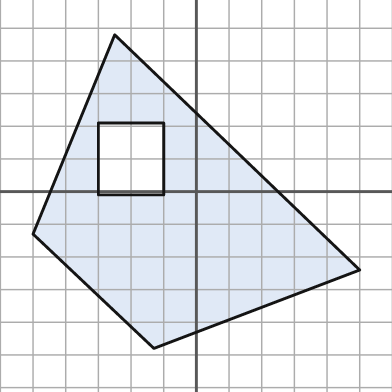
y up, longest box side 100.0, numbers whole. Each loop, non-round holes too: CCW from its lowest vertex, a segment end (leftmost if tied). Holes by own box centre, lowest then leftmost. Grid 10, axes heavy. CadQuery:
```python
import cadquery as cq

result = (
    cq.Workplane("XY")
    .moveTo(-13.0, -48.0)
    .lineTo(50.0, -24.0)
    .lineTo(-25.0, 48.0)
    .lineTo(-50.0, -13.0)
    .close()
    .moveTo(-30.0, -1.0)
    .lineTo(-10.0, -1.0)
    .lineTo(-10.0, 21.0)
    .lineTo(-30.0, 21.0)
    .close()
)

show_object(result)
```